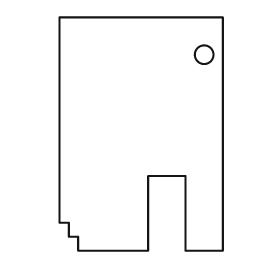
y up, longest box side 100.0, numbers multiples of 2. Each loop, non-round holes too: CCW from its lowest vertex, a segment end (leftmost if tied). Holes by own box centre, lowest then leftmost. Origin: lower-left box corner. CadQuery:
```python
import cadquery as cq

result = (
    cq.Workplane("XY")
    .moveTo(8.0, 0.0)
    .lineTo(38.0, 0.0)
    .lineTo(38.0, 32.0)
    .lineTo(54.0, 32.0)
    .lineTo(54.0, 0.0)
    .lineTo(70.0, 0.0)
    .lineTo(70.0, 100.0)
    .lineTo(0.0, 100.0)
    .lineTo(0.0, 12.0)
    .lineTo(4.0, 12.0)
    .lineTo(4.0, 6.0)
    .lineTo(8.0, 6.0)
    .close()
    .moveTo(62.0, 84.0)
    .circle(4.0)
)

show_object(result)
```